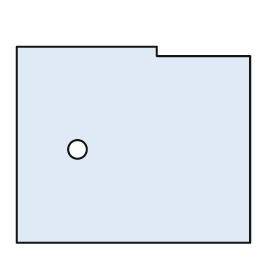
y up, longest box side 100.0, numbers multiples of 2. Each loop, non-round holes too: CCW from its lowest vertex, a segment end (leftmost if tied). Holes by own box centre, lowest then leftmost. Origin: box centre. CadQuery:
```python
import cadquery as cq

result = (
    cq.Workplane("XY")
    .moveTo(-50.0, -42.0)
    .lineTo(50.0, -42.0)
    .lineTo(50.0, 38.0)
    .lineTo(10.0, 38.0)
    .lineTo(10.0, 42.0)
    .lineTo(-50.0, 42.0)
    .close()
    .moveTo(-24.0, -2.0)
    .circle(4.0)
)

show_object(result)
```